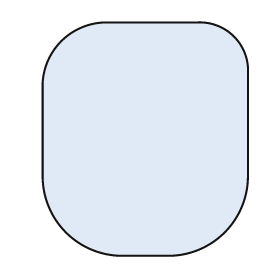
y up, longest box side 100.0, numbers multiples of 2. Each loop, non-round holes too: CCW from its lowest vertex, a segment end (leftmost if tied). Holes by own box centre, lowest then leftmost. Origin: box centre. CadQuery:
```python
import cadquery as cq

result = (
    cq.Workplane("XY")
    .moveTo(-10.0, -50.0)
    .lineTo(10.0, -50.0)
    .threePointArc((34.0, -40.0), (44.0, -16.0))
    .lineTo(44.0, 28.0)
    .threePointArc((38.0, 44.0), (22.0, 50.0))
    .lineTo(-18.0, 50.0)
    .threePointArc((-36.0, 42.0), (-44.0, 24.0))
    .lineTo(-44.0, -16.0)
    .threePointArc((-34.0, -40.0), (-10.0, -50.0))
    .close()
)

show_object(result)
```